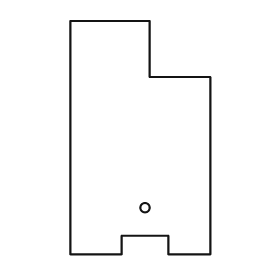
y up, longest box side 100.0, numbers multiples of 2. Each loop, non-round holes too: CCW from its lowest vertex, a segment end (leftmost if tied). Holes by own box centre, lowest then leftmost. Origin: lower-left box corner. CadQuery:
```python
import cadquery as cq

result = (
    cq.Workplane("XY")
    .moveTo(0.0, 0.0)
    .lineTo(22.0, 0.0)
    .lineTo(22.0, 8.0)
    .lineTo(42.0, 8.0)
    .lineTo(42.0, 0.0)
    .lineTo(60.0, 0.0)
    .lineTo(60.0, 76.0)
    .lineTo(34.0, 76.0)
    .lineTo(34.0, 100.0)
    .lineTo(0.0, 100.0)
    .close()
    .moveTo(32.0, 20.0)
    .circle(2.0)
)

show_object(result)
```